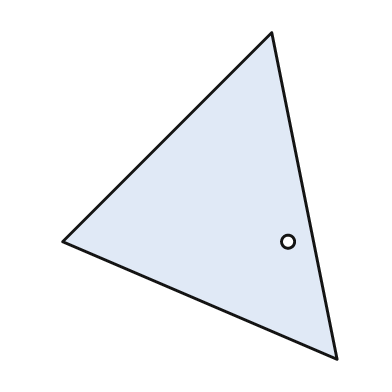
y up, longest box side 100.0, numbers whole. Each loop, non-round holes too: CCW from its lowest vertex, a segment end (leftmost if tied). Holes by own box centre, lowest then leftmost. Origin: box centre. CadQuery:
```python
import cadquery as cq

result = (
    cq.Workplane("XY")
    .moveTo(42.0, -50.0)
    .lineTo(22.0, 50.0)
    .lineTo(-42.0, -14.0)
    .close()
    .moveTo(27.0, -14.0)
    .circle(2.0)
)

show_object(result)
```